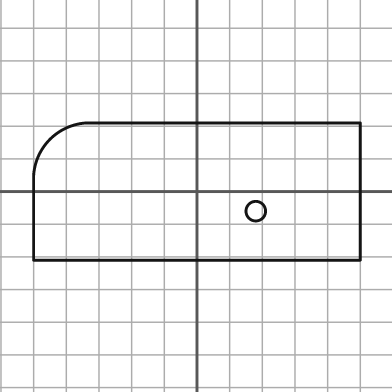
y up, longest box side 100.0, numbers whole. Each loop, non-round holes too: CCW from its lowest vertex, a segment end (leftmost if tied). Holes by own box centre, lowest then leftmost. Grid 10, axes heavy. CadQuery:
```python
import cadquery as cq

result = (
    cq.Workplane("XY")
    .moveTo(-50.0, -21.0)
    .lineTo(50.0, -21.0)
    .lineTo(50.0, 21.0)
    .lineTo(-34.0, 21.0)
    .threePointArc((-45.0, 16.0), (-50.0, 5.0))
    .close()
    .moveTo(18.0, -6.0)
    .circle(3.0)
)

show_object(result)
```